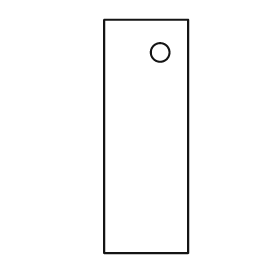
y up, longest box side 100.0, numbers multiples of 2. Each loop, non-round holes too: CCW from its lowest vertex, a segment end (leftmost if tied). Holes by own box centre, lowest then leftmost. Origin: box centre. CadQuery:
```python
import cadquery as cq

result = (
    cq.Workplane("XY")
    .moveTo(-18.0, -50.0)
    .lineTo(18.0, -50.0)
    .lineTo(18.0, 50.0)
    .lineTo(-18.0, 50.0)
    .close()
    .moveTo(6.0, 36.0)
    .circle(4.0)
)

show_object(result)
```